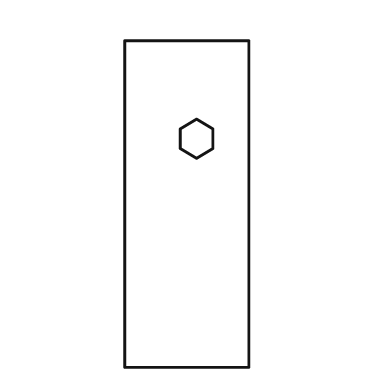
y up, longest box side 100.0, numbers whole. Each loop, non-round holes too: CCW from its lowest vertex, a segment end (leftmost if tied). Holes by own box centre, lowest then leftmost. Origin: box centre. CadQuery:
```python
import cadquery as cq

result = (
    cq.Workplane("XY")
    .moveTo(-19.0, -50.0)
    .lineTo(19.0, -50.0)
    .lineTo(19.0, 50.0)
    .lineTo(-19.0, 50.0)
    .close()
    .moveTo(3.0, 14.0)
    .lineTo(8.0, 17.0)
    .lineTo(8.0, 23.0)
    .lineTo(3.0, 26.0)
    .lineTo(-2.0, 23.0)
    .lineTo(-2.0, 17.0)
    .close()
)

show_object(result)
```